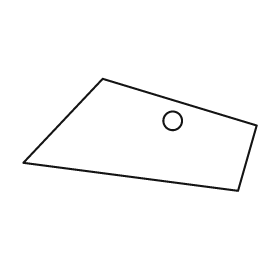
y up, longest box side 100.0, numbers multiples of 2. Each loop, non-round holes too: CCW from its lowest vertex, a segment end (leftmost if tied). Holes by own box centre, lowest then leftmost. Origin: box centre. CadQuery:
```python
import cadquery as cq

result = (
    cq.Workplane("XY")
    .moveTo(42.0, -24.0)
    .lineTo(50.0, 4.0)
    .lineTo(-16.0, 24.0)
    .lineTo(-50.0, -12.0)
    .close()
    .moveTo(14.0, 6.0)
    .circle(4.0)
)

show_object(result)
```